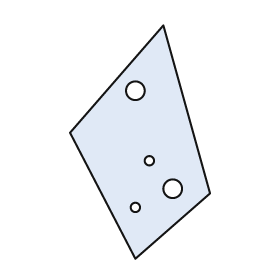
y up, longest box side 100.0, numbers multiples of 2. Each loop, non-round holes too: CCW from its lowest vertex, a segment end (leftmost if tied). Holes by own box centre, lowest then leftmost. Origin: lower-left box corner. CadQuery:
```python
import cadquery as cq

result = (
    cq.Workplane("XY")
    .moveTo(28.0, 0.0)
    .lineTo(60.0, 28.0)
    .lineTo(40.0, 100.0)
    .lineTo(0.0, 54.0)
    .close()
    .moveTo(28.0, 22.0)
    .circle(2.0)
    .moveTo(44.0, 30.0)
    .circle(4.0)
    .moveTo(34.0, 42.0)
    .circle(2.0)
    .moveTo(28.0, 72.0)
    .circle(4.0)
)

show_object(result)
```